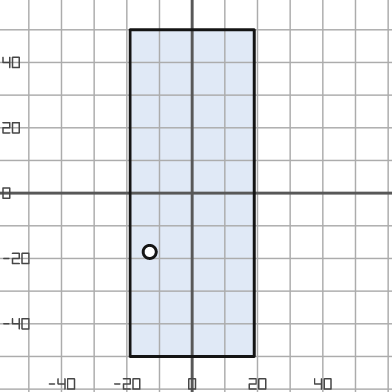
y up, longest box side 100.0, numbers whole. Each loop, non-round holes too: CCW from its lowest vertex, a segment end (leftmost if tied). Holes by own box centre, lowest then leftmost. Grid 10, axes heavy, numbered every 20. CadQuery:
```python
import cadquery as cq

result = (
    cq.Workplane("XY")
    .moveTo(-19.0, -50.0)
    .lineTo(19.0, -50.0)
    .lineTo(19.0, 50.0)
    .lineTo(-19.0, 50.0)
    .close()
    .moveTo(-13.0, -18.0)
    .circle(2.0)
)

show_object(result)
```